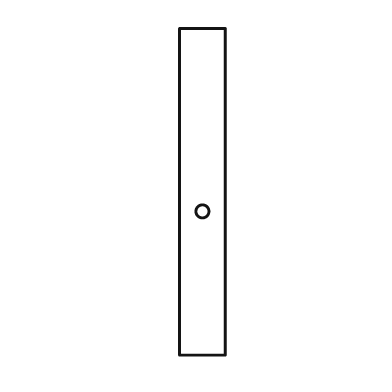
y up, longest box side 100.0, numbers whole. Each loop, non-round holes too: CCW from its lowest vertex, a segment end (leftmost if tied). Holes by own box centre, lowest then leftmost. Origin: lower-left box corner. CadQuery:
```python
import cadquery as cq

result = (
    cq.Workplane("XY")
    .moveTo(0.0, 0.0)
    .lineTo(14.0, 0.0)
    .lineTo(14.0, 100.0)
    .lineTo(0.0, 100.0)
    .close()
    .moveTo(7.0, 44.0)
    .circle(2.0)
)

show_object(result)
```